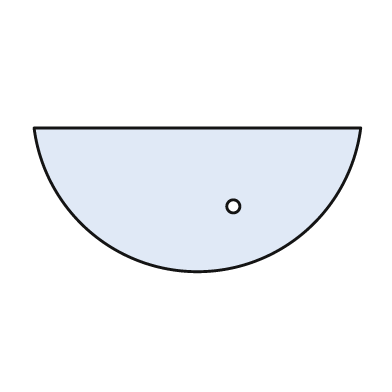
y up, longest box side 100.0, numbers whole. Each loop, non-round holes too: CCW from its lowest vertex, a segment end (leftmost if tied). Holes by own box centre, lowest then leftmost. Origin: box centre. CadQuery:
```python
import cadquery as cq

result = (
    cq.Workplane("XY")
    .moveTo(-50.0, 22.0)
    .threePointArc((0.0, -22.0), (50.0, 22.0))
    .close()
    .moveTo(11.0, -2.0)
    .circle(2.0)
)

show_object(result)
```